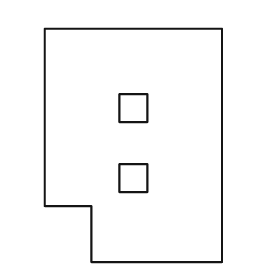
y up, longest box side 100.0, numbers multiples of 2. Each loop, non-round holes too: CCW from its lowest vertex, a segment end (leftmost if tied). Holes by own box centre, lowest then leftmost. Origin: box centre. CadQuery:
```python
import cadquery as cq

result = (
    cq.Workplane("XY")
    .moveTo(-18.0, -50.0)
    .lineTo(38.0, -50.0)
    .lineTo(38.0, 50.0)
    .lineTo(-38.0, 50.0)
    .lineTo(-38.0, -26.0)
    .lineTo(-18.0, -26.0)
    .close()
    .moveTo(-6.0, -20.0)
    .lineTo(6.0, -20.0)
    .lineTo(6.0, -8.0)
    .lineTo(-6.0, -8.0)
    .close()
    .moveTo(-6.0, 10.0)
    .lineTo(6.0, 10.0)
    .lineTo(6.0, 22.0)
    .lineTo(-6.0, 22.0)
    .close()
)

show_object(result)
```